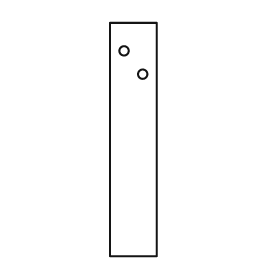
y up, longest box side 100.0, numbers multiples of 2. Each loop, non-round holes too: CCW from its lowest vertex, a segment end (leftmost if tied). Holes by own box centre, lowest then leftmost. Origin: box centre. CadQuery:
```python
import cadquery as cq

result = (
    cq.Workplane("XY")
    .moveTo(-10.0, -50.0)
    .lineTo(10.0, -50.0)
    .lineTo(10.0, 50.0)
    .lineTo(-10.0, 50.0)
    .close()
    .moveTo(4.0, 28.0)
    .circle(2.0)
    .moveTo(-4.0, 38.0)
    .circle(2.0)
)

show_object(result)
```